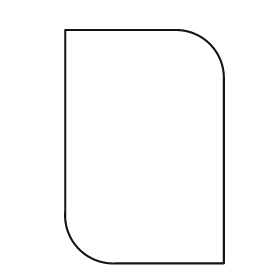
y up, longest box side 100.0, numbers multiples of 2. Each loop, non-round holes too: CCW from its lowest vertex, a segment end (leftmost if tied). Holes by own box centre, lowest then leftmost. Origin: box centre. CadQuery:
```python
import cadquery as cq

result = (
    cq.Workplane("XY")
    .moveTo(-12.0, -50.0)
    .lineTo(34.0, -50.0)
    .lineTo(34.0, 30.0)
    .threePointArc((28.0, 44.0), (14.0, 50.0))
    .lineTo(-34.0, 50.0)
    .lineTo(-34.0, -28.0)
    .threePointArc((-28.0, -44.0), (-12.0, -50.0))
    .close()
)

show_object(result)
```